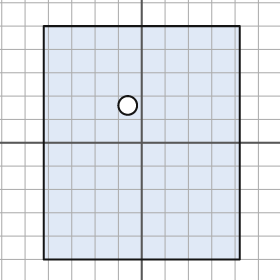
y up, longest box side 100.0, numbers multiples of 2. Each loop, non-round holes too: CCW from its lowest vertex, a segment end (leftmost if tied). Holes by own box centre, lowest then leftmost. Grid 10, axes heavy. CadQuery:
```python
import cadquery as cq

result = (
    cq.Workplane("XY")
    .moveTo(-42.0, -50.0)
    .lineTo(42.0, -50.0)
    .lineTo(42.0, 50.0)
    .lineTo(-42.0, 50.0)
    .close()
    .moveTo(-6.0, 16.0)
    .circle(4.0)
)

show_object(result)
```